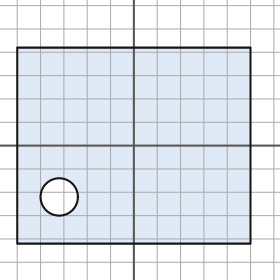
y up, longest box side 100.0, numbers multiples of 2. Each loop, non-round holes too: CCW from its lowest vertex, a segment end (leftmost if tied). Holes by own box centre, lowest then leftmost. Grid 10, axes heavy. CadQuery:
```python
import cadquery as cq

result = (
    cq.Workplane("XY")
    .moveTo(-50.0, -42.0)
    .lineTo(50.0, -42.0)
    .lineTo(50.0, 42.0)
    .lineTo(-50.0, 42.0)
    .close()
    .moveTo(-32.0, -22.0)
    .circle(8.0)
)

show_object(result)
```